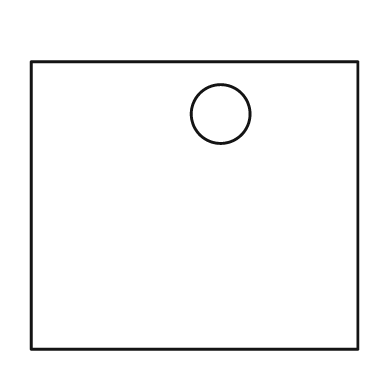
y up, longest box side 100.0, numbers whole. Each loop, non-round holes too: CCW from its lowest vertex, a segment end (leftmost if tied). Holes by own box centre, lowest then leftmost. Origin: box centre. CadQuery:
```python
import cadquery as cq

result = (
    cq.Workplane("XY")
    .moveTo(-50.0, -44.0)
    .lineTo(50.0, -44.0)
    .lineTo(50.0, 44.0)
    .lineTo(-50.0, 44.0)
    .close()
    .moveTo(8.0, 28.0)
    .circle(9.0)
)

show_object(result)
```